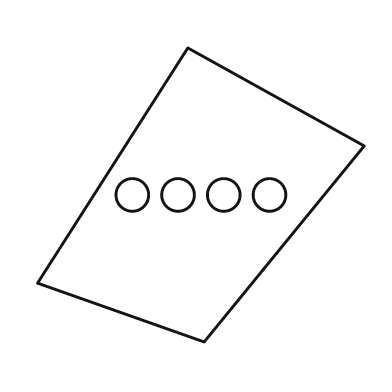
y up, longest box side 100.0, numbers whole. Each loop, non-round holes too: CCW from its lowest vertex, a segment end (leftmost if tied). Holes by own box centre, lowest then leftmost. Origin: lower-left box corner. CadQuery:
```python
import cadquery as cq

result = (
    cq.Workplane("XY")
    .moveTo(51.0, 0.0)
    .lineTo(100.0, 60.0)
    .lineTo(46.0, 90.0)
    .lineTo(0.0, 18.0)
    .close()
    .moveTo(29.0, 45.0)
    .circle(5.0)
    .moveTo(43.0, 45.0)
    .circle(5.0)
    .moveTo(57.0, 45.0)
    .circle(5.0)
    .moveTo(71.0, 45.0)
    .circle(5.0)
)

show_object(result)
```